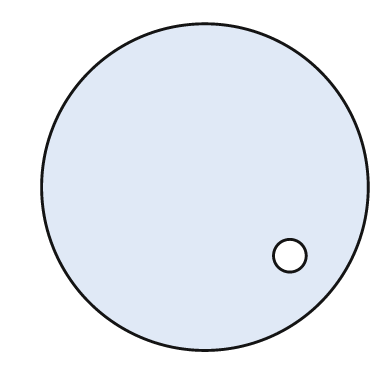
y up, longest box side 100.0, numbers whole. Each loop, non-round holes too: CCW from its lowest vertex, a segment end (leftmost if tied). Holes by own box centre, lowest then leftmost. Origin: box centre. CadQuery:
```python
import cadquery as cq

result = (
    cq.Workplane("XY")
    .moveTo(0.0, 0.0)
    .circle(50.0)
    .moveTo(26.0, -21.0)
    .circle(5.0)
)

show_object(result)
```